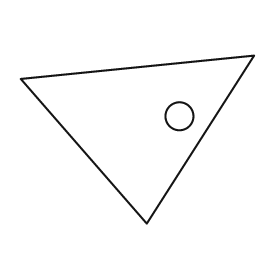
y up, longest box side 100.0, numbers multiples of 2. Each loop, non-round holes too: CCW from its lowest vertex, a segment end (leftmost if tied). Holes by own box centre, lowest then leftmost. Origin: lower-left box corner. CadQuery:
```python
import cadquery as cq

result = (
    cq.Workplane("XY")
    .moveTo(54.0, 0.0)
    .lineTo(100.0, 72.0)
    .lineTo(0.0, 62.0)
    .close()
    .moveTo(68.0, 46.0)
    .circle(6.0)
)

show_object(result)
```